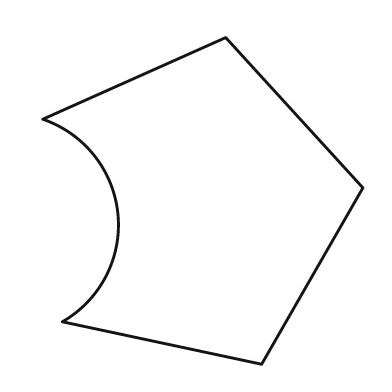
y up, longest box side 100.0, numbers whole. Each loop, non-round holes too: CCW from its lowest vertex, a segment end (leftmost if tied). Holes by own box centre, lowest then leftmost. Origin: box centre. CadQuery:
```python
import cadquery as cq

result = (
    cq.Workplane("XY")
    .moveTo(18.0, -50.0)
    .lineTo(49.0, 4.0)
    .lineTo(7.0, 50.0)
    .lineTo(-49.0, 25.0)
    .threePointArc((-26.0, -4.0), (-43.0, -37.0))
    .close()
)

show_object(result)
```